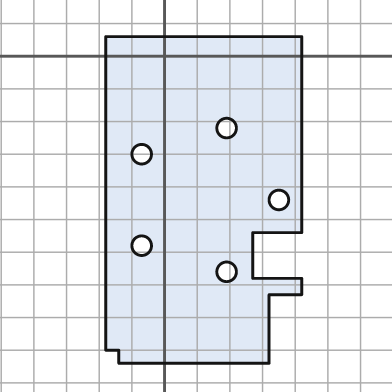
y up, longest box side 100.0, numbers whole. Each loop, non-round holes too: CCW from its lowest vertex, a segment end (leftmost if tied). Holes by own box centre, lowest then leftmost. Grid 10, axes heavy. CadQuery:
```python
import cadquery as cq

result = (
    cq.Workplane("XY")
    .moveTo(-14.0, -94.0)
    .lineTo(32.0, -94.0)
    .lineTo(32.0, -73.0)
    .lineTo(42.0, -73.0)
    .lineTo(42.0, -68.0)
    .lineTo(27.0, -68.0)
    .lineTo(27.0, -54.0)
    .lineTo(42.0, -54.0)
    .lineTo(42.0, 6.0)
    .lineTo(-18.0, 6.0)
    .lineTo(-18.0, -90.0)
    .lineTo(-14.0, -90.0)
    .close()
    .moveTo(19.0, -66.0)
    .circle(3.0)
    .moveTo(-7.0, -58.0)
    .circle(3.0)
    .moveTo(35.0, -44.0)
    .circle(3.0)
    .moveTo(-7.0, -30.0)
    .circle(3.0)
    .moveTo(19.0, -22.0)
    .circle(3.0)
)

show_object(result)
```